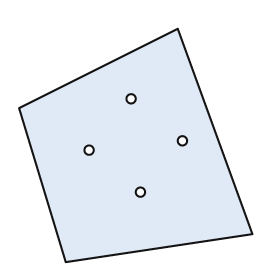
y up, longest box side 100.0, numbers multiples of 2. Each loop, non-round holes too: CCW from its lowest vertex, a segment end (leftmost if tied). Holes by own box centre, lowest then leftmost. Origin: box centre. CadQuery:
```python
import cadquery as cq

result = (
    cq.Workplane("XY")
    .moveTo(-30.0, -50.0)
    .lineTo(50.0, -38.0)
    .lineTo(18.0, 50.0)
    .lineTo(-50.0, 16.0)
    .close()
    .moveTo(2.0, -20.0)
    .circle(2.0)
    .moveTo(-20.0, -2.0)
    .circle(2.0)
    .moveTo(20.0, 2.0)
    .circle(2.0)
    .moveTo(-2.0, 20.0)
    .circle(2.0)
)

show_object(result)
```